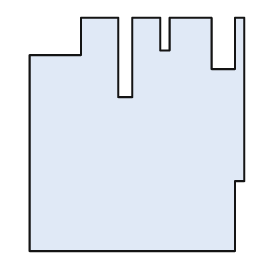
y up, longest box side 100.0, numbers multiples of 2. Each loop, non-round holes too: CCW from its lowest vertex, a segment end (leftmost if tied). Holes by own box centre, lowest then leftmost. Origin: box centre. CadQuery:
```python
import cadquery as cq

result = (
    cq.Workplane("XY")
    .moveTo(-46.0, -50.0)
    .lineTo(42.0, -50.0)
    .lineTo(42.0, -20.0)
    .lineTo(46.0, -20.0)
    .lineTo(46.0, 50.0)
    .lineTo(42.0, 50.0)
    .lineTo(42.0, 28.0)
    .lineTo(32.0, 28.0)
    .lineTo(32.0, 50.0)
    .lineTo(14.0, 50.0)
    .lineTo(14.0, 36.0)
    .lineTo(10.0, 36.0)
    .lineTo(10.0, 50.0)
    .lineTo(-2.0, 50.0)
    .lineTo(-2.0, 16.0)
    .lineTo(-8.0, 16.0)
    .lineTo(-8.0, 50.0)
    .lineTo(-24.0, 50.0)
    .lineTo(-24.0, 34.0)
    .lineTo(-46.0, 34.0)
    .close()
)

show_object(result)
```